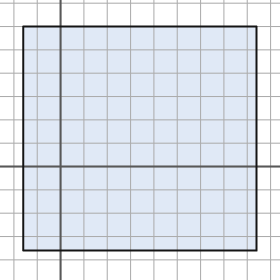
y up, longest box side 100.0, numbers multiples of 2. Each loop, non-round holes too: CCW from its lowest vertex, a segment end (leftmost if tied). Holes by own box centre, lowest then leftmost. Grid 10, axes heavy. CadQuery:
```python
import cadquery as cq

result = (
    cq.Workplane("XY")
    .moveTo(-16.0, -36.0)
    .lineTo(84.0, -36.0)
    .lineTo(84.0, 60.0)
    .lineTo(-16.0, 60.0)
    .close()
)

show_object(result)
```